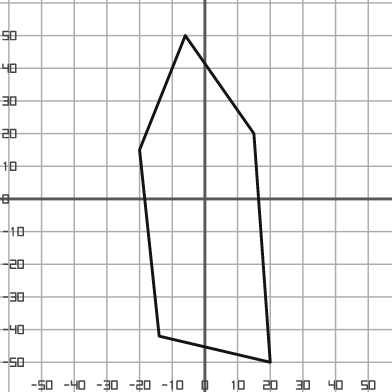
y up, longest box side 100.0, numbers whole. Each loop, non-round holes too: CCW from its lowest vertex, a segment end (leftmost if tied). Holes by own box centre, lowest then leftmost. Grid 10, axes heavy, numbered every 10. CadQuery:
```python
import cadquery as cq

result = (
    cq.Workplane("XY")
    .moveTo(20.0, -50.0)
    .lineTo(15.0, 20.0)
    .lineTo(-6.0, 50.0)
    .lineTo(-20.0, 15.0)
    .lineTo(-14.0, -42.0)
    .close()
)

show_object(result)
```